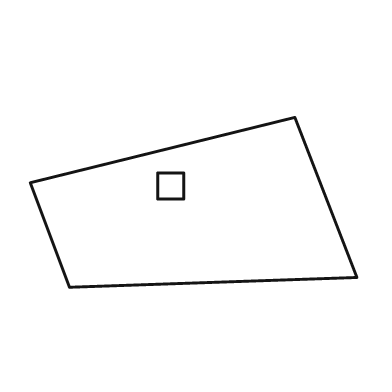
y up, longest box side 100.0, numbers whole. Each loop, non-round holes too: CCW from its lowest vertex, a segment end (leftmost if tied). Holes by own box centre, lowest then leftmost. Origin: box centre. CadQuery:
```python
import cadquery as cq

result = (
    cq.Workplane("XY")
    .moveTo(-38.0, -26.0)
    .lineTo(50.0, -23.0)
    .lineTo(31.0, 26.0)
    .lineTo(-50.0, 6.0)
    .close()
    .moveTo(-11.0, 1.0)
    .lineTo(-3.0, 1.0)
    .lineTo(-3.0, 9.0)
    .lineTo(-11.0, 9.0)
    .close()
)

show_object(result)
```